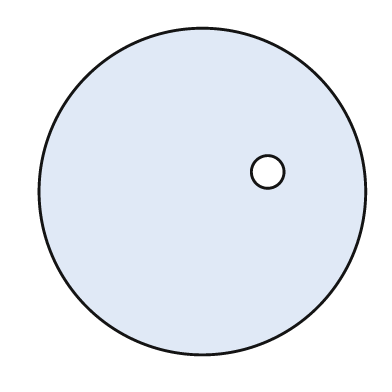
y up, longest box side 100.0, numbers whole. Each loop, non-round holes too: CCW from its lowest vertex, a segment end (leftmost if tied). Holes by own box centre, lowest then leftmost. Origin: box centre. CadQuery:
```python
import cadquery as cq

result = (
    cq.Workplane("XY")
    .moveTo(0.0, 0.0)
    .circle(50.0)
    .moveTo(20.0, 6.0)
    .circle(5.0)
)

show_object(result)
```